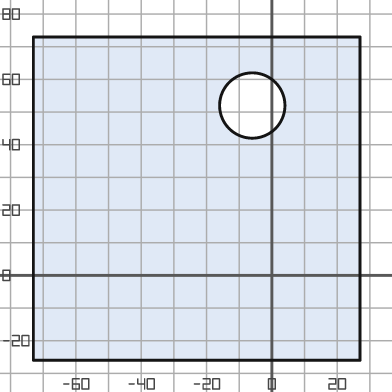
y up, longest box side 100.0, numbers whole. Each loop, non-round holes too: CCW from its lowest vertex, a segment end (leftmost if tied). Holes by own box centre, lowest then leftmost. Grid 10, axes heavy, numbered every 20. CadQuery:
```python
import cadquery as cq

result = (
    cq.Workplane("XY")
    .moveTo(-73.0, -26.0)
    .lineTo(27.0, -26.0)
    .lineTo(27.0, 73.0)
    .lineTo(-73.0, 73.0)
    .close()
    .moveTo(-6.0, 52.0)
    .circle(10.0)
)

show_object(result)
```